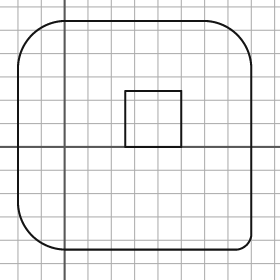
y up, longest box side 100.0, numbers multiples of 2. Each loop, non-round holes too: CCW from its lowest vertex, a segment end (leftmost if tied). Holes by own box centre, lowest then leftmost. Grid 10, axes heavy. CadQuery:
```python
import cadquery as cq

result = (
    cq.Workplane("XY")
    .moveTo(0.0, -44.0)
    .lineTo(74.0, -44.0)
    .threePointArc((78.0, -42.0), (80.0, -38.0))
    .lineTo(80.0, 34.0)
    .threePointArc((74.0, 48.0), (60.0, 54.0))
    .lineTo(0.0, 54.0)
    .threePointArc((-14.0, 48.0), (-20.0, 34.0))
    .lineTo(-20.0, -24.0)
    .threePointArc((-14.0, -38.0), (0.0, -44.0))
    .close()
    .moveTo(26.0, 0.0)
    .lineTo(50.0, 0.0)
    .lineTo(50.0, 24.0)
    .lineTo(26.0, 24.0)
    .close()
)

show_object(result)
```